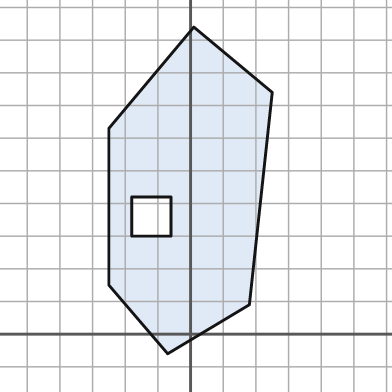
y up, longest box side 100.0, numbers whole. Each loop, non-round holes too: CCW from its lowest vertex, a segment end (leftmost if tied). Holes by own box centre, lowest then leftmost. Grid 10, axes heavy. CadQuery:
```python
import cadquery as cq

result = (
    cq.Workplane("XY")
    .moveTo(-7.0, -6.0)
    .lineTo(18.0, 9.0)
    .lineTo(25.0, 74.0)
    .lineTo(1.0, 94.0)
    .lineTo(-25.0, 63.0)
    .lineTo(-25.0, 15.0)
    .close()
    .moveTo(-18.0, 30.0)
    .lineTo(-6.0, 30.0)
    .lineTo(-6.0, 42.0)
    .lineTo(-18.0, 42.0)
    .close()
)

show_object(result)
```